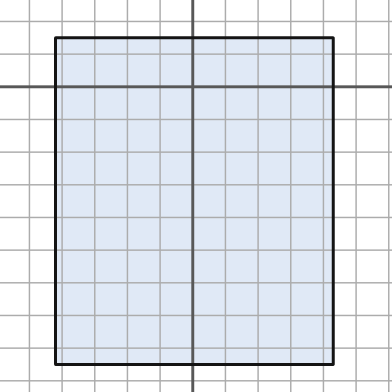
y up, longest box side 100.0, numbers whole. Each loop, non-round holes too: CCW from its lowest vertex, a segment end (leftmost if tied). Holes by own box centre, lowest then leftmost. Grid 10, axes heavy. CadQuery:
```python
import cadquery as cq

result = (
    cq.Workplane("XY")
    .moveTo(-42.0, -85.0)
    .lineTo(43.0, -85.0)
    .lineTo(43.0, 15.0)
    .lineTo(-42.0, 15.0)
    .close()
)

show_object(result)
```